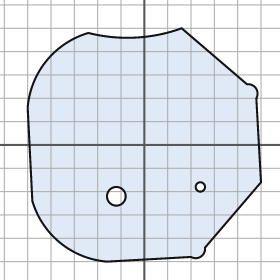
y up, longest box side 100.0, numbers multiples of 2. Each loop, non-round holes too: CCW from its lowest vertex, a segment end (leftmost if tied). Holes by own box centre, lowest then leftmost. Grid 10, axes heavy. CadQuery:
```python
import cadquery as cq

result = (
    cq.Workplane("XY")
    .moveTo(-16.0, -50.0)
    .lineTo(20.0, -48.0)
    .threePointArc((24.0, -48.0), (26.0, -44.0))
    .lineTo(50.0, -16.0)
    .lineTo(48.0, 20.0)
    .threePointArc((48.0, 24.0), (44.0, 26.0))
    .lineTo(16.0, 50.0)
    .threePointArc((-4.0, 46.0), (-24.0, 48.0))
    .threePointArc((-42.0, 36.0), (-50.0, 16.0))
    .lineTo(-48.0, -24.0)
    .threePointArc((-36.0, -42.0), (-16.0, -50.0))
    .close()
    .moveTo(-12.0, -22.0)
    .circle(4.0)
    .moveTo(24.0, -18.0)
    .circle(2.0)
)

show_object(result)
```